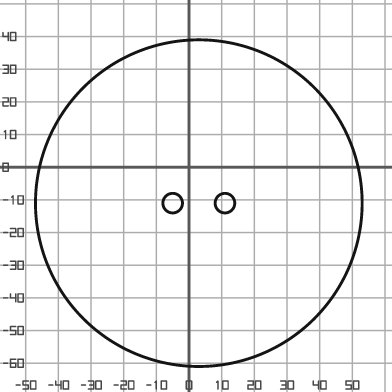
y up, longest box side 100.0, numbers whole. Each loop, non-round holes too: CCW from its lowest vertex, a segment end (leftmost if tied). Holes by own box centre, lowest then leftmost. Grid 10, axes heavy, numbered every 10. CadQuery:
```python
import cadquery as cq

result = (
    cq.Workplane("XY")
    .moveTo(3.0, -11.0)
    .circle(50.0)
    .moveTo(-5.0, -11.0)
    .circle(3.0)
    .moveTo(11.0, -11.0)
    .circle(3.0)
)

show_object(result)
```